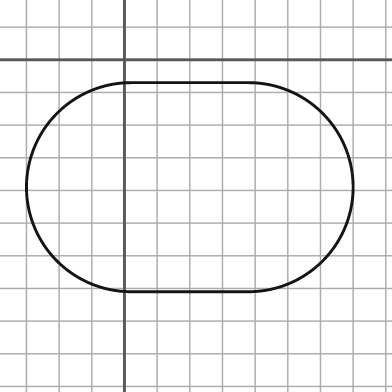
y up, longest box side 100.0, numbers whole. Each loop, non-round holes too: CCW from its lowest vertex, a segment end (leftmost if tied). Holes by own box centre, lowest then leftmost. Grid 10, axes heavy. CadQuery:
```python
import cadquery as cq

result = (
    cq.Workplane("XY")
    .moveTo(2.0, -71.0)
    .lineTo(38.0, -71.0)
    .threePointArc((70.0, -39.0), (38.0, -7.0))
    .lineTo(2.0, -7.0)
    .threePointArc((-30.0, -39.0), (2.0, -71.0))
    .close()
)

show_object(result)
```